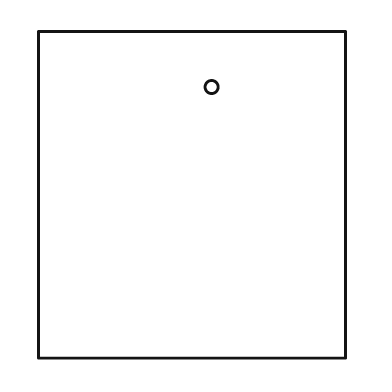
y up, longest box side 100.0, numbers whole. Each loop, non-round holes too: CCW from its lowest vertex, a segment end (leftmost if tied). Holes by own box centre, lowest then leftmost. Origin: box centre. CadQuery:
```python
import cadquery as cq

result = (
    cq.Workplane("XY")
    .moveTo(-47.0, -50.0)
    .lineTo(47.0, -50.0)
    .lineTo(47.0, 50.0)
    .lineTo(-47.0, 50.0)
    .close()
    .moveTo(6.0, 33.0)
    .circle(2.0)
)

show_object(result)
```